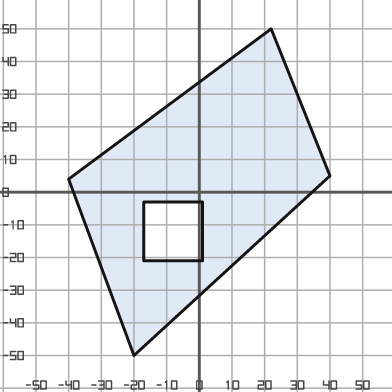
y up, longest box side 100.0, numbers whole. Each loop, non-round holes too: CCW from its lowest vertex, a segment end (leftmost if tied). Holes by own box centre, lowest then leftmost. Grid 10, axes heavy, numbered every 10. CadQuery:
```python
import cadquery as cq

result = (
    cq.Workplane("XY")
    .moveTo(-20.0, -50.0)
    .lineTo(40.0, 5.0)
    .lineTo(22.0, 50.0)
    .lineTo(-40.0, 4.0)
    .close()
    .moveTo(-17.0, -21.0)
    .lineTo(1.0, -21.0)
    .lineTo(1.0, -3.0)
    .lineTo(-17.0, -3.0)
    .close()
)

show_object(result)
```